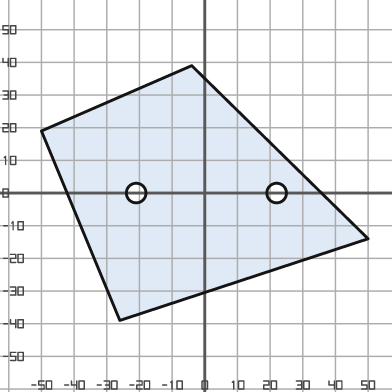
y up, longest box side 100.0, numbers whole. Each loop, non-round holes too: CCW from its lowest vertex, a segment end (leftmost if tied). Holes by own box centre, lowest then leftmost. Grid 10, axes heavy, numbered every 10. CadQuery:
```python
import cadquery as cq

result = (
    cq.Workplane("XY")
    .moveTo(-26.0, -39.0)
    .lineTo(50.0, -14.0)
    .lineTo(-4.0, 39.0)
    .lineTo(-50.0, 19.0)
    .close()
    .moveTo(-21.0, 0.0)
    .circle(3.0)
    .moveTo(22.0, 0.0)
    .circle(3.0)
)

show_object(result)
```